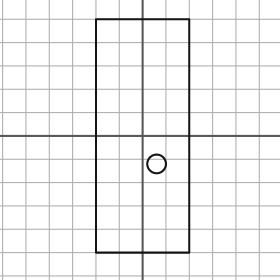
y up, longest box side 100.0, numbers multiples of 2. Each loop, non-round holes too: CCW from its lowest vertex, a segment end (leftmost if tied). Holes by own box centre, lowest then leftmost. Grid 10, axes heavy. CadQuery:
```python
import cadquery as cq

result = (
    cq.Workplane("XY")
    .moveTo(-20.0, -50.0)
    .lineTo(20.0, -50.0)
    .lineTo(20.0, 50.0)
    .lineTo(-20.0, 50.0)
    .close()
    .moveTo(6.0, -12.0)
    .circle(4.0)
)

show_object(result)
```